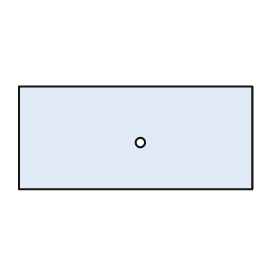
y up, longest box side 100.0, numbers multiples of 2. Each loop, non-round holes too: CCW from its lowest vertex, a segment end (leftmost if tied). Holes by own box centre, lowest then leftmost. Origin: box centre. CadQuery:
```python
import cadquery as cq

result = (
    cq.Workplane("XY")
    .moveTo(-50.0, -22.0)
    .lineTo(50.0, -22.0)
    .lineTo(50.0, 22.0)
    .lineTo(-50.0, 22.0)
    .close()
    .moveTo(2.0, -2.0)
    .circle(2.0)
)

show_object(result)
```